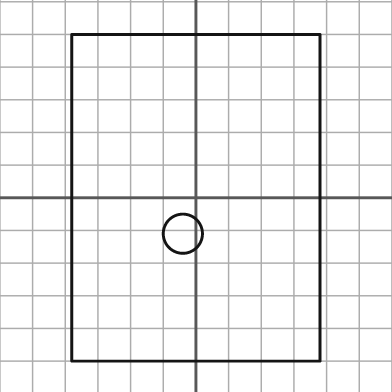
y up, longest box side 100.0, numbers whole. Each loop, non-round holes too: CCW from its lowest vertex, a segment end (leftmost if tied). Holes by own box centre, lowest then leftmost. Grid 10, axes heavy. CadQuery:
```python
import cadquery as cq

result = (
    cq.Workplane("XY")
    .moveTo(-38.0, -50.0)
    .lineTo(38.0, -50.0)
    .lineTo(38.0, 50.0)
    .lineTo(-38.0, 50.0)
    .close()
    .moveTo(-4.0, -11.0)
    .circle(6.0)
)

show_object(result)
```